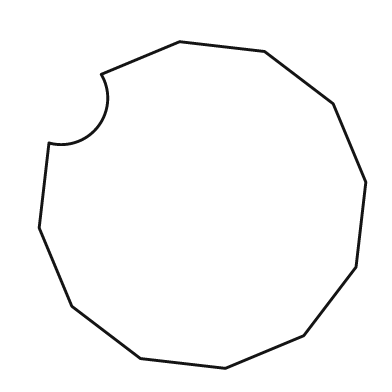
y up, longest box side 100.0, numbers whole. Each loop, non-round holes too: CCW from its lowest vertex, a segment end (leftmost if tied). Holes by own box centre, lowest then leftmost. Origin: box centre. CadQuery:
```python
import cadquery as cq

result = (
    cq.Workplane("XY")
    .moveTo(7.0, -50.0)
    .lineTo(31.0, -40.0)
    .lineTo(47.0, -19.0)
    .lineTo(50.0, 7.0)
    .lineTo(40.0, 31.0)
    .lineTo(19.0, 47.0)
    .lineTo(-7.0, 50.0)
    .lineTo(-31.0, 40.0)
    .threePointArc((-32.0, 24.0), (-47.0, 19.0))
    .lineTo(-50.0, -7.0)
    .lineTo(-40.0, -31.0)
    .lineTo(-19.0, -47.0)
    .close()
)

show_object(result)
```